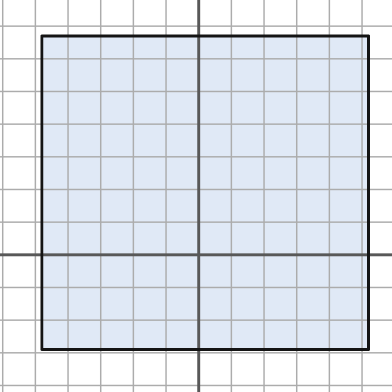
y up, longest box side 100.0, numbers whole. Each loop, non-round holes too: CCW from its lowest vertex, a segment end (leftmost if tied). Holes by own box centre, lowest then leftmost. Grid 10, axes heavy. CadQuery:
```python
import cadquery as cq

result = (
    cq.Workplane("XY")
    .moveTo(-48.0, -29.0)
    .lineTo(52.0, -29.0)
    .lineTo(52.0, 67.0)
    .lineTo(-48.0, 67.0)
    .close()
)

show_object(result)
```